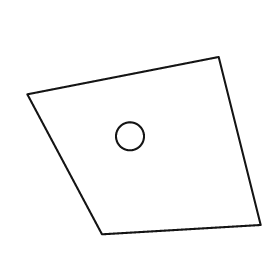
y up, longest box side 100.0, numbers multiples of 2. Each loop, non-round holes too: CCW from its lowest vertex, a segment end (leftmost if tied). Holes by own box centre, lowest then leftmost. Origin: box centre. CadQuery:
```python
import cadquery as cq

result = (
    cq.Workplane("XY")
    .moveTo(-18.0, -38.0)
    .lineTo(50.0, -34.0)
    .lineTo(32.0, 38.0)
    .lineTo(-50.0, 22.0)
    .close()
    .moveTo(-6.0, 4.0)
    .circle(6.0)
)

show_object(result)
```